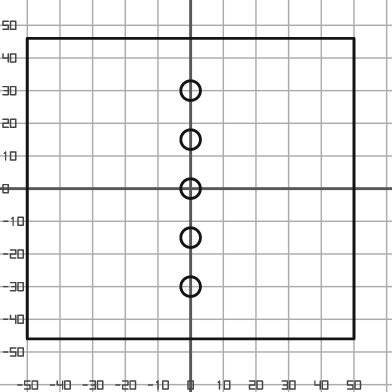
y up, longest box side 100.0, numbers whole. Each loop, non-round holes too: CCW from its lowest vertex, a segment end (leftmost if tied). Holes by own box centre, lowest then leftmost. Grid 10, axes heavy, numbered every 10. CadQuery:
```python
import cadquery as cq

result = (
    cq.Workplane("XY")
    .moveTo(-50.0, -46.0)
    .lineTo(50.0, -46.0)
    .lineTo(50.0, 46.0)
    .lineTo(-50.0, 46.0)
    .close()
    .moveTo(0.0, -30.0)
    .circle(3.0)
    .moveTo(0.0, -15.0)
    .circle(3.0)
    .moveTo(0.0, 0.0)
    .circle(3.0)
    .moveTo(0.0, 15.0)
    .circle(3.0)
    .moveTo(0.0, 30.0)
    .circle(3.0)
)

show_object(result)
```